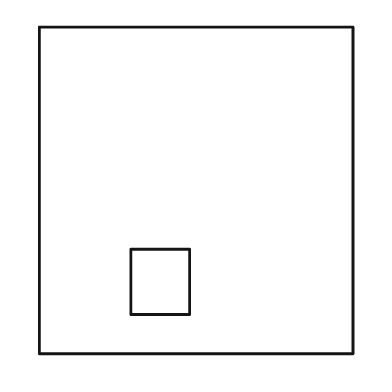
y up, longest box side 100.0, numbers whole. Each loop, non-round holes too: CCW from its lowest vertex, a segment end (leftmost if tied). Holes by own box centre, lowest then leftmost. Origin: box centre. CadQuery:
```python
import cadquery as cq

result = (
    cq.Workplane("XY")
    .moveTo(-48.0, -50.0)
    .lineTo(48.0, -50.0)
    .lineTo(48.0, 50.0)
    .lineTo(-48.0, 50.0)
    .close()
    .moveTo(-20.0, -38.0)
    .lineTo(-2.0, -38.0)
    .lineTo(-2.0, -18.0)
    .lineTo(-20.0, -18.0)
    .close()
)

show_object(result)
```